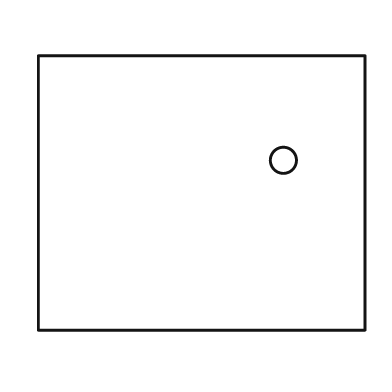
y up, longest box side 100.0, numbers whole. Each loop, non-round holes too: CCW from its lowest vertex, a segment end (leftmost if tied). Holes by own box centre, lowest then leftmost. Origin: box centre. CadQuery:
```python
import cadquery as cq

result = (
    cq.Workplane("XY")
    .moveTo(-50.0, -42.0)
    .lineTo(50.0, -42.0)
    .lineTo(50.0, 42.0)
    .lineTo(-50.0, 42.0)
    .close()
    .moveTo(25.0, 10.0)
    .circle(4.0)
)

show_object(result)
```